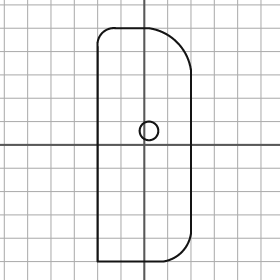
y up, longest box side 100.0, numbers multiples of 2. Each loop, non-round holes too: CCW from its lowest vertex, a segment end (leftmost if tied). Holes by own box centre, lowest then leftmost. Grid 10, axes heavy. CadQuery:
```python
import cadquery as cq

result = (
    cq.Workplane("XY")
    .moveTo(-20.0, -50.0)
    .lineTo(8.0, -50.0)
    .threePointArc((16.0, -46.0), (20.0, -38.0))
    .lineTo(20.0, 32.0)
    .threePointArc((14.0, 44.0), (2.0, 50.0))
    .lineTo(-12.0, 50.0)
    .threePointArc((-18.0, 48.0), (-20.0, 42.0))
    .close()
    .moveTo(2.0, 6.0)
    .circle(4.0)
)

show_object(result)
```